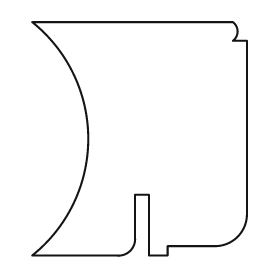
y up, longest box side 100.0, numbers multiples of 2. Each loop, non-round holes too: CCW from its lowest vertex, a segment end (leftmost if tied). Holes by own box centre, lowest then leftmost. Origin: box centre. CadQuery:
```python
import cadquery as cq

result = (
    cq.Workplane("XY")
    .moveTo(-46.0, -50.0)
    .lineTo(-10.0, -50.0)
    .threePointArc((-4.0, -48.0), (-2.0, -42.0))
    .lineTo(-2.0, -24.0)
    .lineTo(4.0, -24.0)
    .lineTo(4.0, -50.0)
    .lineTo(12.0, -50.0)
    .lineTo(12.0, -46.0)
    .lineTo(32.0, -46.0)
    .threePointArc((42.0, -42.0), (46.0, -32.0))
    .lineTo(46.0, 42.0)
    .lineTo(40.0, 42.0)
    .threePointArc((42.0, 46.0), (40.0, 50.0))
    .lineTo(-46.0, 50.0)
    .threePointArc((-22.0, 0.0), (-46.0, -50.0))
    .close()
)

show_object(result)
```